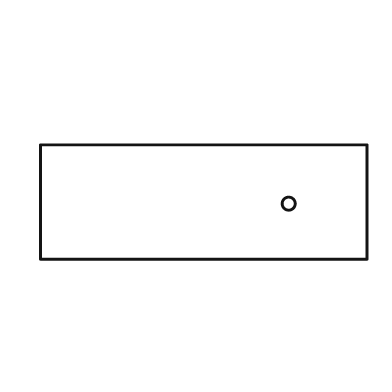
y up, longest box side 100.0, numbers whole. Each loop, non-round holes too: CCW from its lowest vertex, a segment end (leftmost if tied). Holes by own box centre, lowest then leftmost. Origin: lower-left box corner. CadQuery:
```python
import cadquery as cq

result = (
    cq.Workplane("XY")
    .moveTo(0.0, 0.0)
    .lineTo(100.0, 0.0)
    .lineTo(100.0, 35.0)
    .lineTo(0.0, 35.0)
    .close()
    .moveTo(76.0, 17.0)
    .circle(2.0)
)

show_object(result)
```